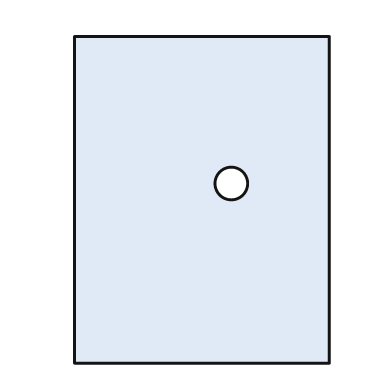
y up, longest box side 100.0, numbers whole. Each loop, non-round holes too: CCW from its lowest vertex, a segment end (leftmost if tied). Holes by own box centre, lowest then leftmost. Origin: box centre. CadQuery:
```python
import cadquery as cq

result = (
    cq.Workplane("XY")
    .moveTo(-39.0, -50.0)
    .lineTo(39.0, -50.0)
    .lineTo(39.0, 50.0)
    .lineTo(-39.0, 50.0)
    .close()
    .moveTo(9.0, 5.0)
    .circle(5.0)
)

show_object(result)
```